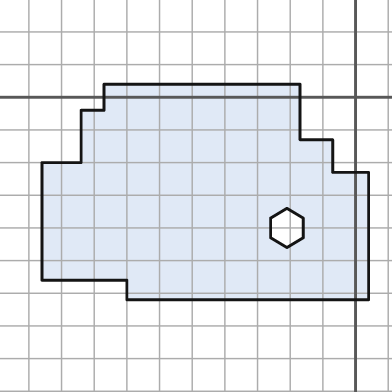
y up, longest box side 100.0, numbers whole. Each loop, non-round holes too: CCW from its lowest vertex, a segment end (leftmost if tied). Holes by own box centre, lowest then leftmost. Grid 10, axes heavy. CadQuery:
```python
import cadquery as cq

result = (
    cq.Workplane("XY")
    .moveTo(-70.0, -62.0)
    .lineTo(4.0, -62.0)
    .lineTo(4.0, -23.0)
    .lineTo(-7.0, -23.0)
    .lineTo(-7.0, -13.0)
    .lineTo(-17.0, -13.0)
    .lineTo(-17.0, 4.0)
    .lineTo(-77.0, 4.0)
    .lineTo(-77.0, -4.0)
    .lineTo(-84.0, -4.0)
    .lineTo(-84.0, -20.0)
    .lineTo(-96.0, -20.0)
    .lineTo(-96.0, -56.0)
    .lineTo(-70.0, -56.0)
    .close()
    .moveTo(-21.0, -46.0)
    .lineTo(-16.0, -43.0)
    .lineTo(-16.0, -37.0)
    .lineTo(-21.0, -34.0)
    .lineTo(-26.0, -37.0)
    .lineTo(-26.0, -43.0)
    .close()
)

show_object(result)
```